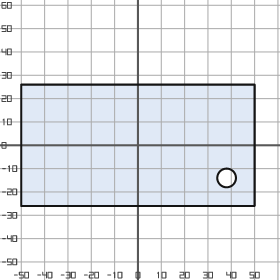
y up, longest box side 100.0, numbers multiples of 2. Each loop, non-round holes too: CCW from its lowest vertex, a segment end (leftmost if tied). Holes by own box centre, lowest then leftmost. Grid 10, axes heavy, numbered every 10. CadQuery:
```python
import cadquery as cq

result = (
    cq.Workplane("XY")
    .moveTo(-50.0, -26.0)
    .lineTo(50.0, -26.0)
    .lineTo(50.0, 26.0)
    .lineTo(-50.0, 26.0)
    .close()
    .moveTo(38.0, -14.0)
    .circle(4.0)
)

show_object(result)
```